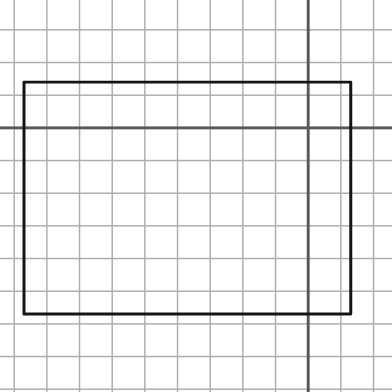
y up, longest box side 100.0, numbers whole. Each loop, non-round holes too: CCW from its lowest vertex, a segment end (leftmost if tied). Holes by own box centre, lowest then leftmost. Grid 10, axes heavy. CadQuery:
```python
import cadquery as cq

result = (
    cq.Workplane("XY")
    .moveTo(-87.0, -57.0)
    .lineTo(13.0, -57.0)
    .lineTo(13.0, 14.0)
    .lineTo(-87.0, 14.0)
    .close()
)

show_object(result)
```